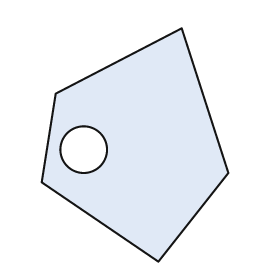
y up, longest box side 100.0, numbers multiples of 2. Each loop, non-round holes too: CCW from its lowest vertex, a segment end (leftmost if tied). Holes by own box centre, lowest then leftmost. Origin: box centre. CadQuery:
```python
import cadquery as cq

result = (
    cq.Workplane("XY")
    .moveTo(10.0, -50.0)
    .lineTo(40.0, -12.0)
    .lineTo(20.0, 50.0)
    .lineTo(-34.0, 22.0)
    .lineTo(-40.0, -16.0)
    .close()
    .moveTo(-22.0, -2.0)
    .circle(10.0)
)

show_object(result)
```